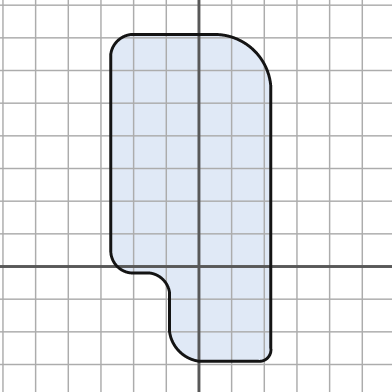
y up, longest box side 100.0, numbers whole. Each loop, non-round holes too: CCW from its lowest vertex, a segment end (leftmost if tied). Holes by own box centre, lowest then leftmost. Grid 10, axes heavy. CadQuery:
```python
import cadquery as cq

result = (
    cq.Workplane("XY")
    .moveTo(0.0, -29.0)
    .lineTo(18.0, -29.0)
    .threePointArc((21.0, -28.0), (22.0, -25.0))
    .lineTo(22.0, 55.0)
    .threePointArc((17.0, 66.0), (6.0, 71.0))
    .lineTo(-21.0, 71.0)
    .threePointArc((-25.0, 69.0), (-27.0, 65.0))
    .lineTo(-27.0, 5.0)
    .threePointArc((-25.0, 0.0), (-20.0, -2.0))
    .lineTo(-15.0, -2.0)
    .threePointArc((-11.0, -4.0), (-9.0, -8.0))
    .lineTo(-9.0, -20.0)
    .threePointArc((-6.0, -26.0), (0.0, -29.0))
    .close()
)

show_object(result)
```